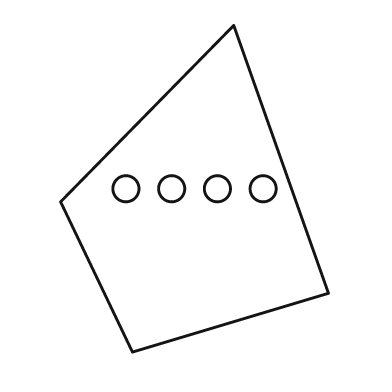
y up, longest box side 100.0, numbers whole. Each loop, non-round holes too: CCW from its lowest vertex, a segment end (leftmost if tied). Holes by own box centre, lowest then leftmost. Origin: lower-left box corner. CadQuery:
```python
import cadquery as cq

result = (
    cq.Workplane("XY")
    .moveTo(22.0, 0.0)
    .lineTo(82.0, 18.0)
    .lineTo(53.0, 100.0)
    .lineTo(0.0, 46.0)
    .close()
    .moveTo(20.0, 50.0)
    .circle(4.0)
    .moveTo(34.0, 50.0)
    .circle(4.0)
    .moveTo(48.0, 50.0)
    .circle(4.0)
    .moveTo(62.0, 50.0)
    .circle(4.0)
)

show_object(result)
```